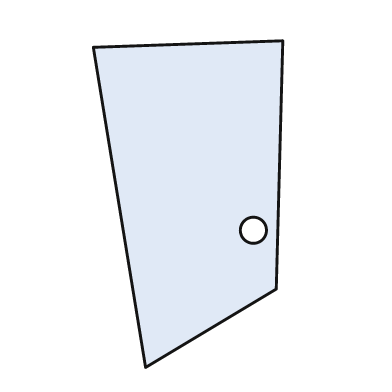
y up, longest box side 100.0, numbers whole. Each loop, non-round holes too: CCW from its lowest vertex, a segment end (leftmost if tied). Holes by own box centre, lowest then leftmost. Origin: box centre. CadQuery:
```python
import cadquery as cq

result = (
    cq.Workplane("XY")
    .moveTo(-13.0, -50.0)
    .lineTo(27.0, -26.0)
    .lineTo(29.0, 50.0)
    .lineTo(-29.0, 48.0)
    .close()
    .moveTo(20.0, -8.0)
    .circle(4.0)
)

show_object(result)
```